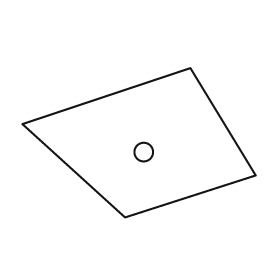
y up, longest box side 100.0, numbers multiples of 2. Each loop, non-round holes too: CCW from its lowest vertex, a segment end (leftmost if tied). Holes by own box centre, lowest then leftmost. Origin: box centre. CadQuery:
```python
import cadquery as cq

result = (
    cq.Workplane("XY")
    .moveTo(-6.0, -32.0)
    .lineTo(50.0, -14.0)
    .lineTo(22.0, 32.0)
    .lineTo(-50.0, 8.0)
    .close()
    .moveTo(2.0, -4.0)
    .circle(4.0)
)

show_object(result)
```